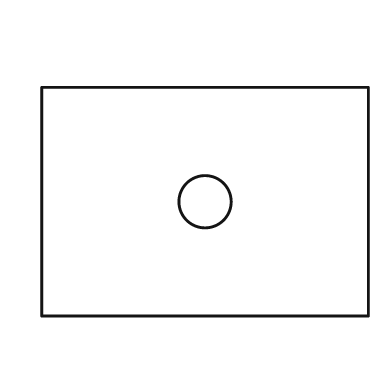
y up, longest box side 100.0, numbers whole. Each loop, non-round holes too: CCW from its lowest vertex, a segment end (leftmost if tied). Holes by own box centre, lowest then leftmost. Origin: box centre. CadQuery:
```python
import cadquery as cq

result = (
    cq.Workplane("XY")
    .moveTo(-50.0, -35.0)
    .lineTo(50.0, -35.0)
    .lineTo(50.0, 35.0)
    .lineTo(-50.0, 35.0)
    .close()
    .moveTo(0.0, 0.0)
    .circle(8.0)
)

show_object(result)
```